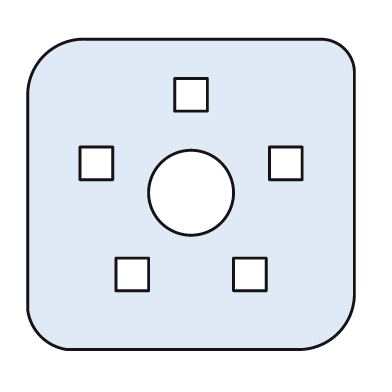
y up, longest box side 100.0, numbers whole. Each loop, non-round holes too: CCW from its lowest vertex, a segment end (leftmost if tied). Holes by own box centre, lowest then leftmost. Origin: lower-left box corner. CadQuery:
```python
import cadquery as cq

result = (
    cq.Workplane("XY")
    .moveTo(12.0, 0.0)
    .lineTo(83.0, 0.0)
    .threePointArc((95.0, 5.0), (100.0, 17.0))
    .lineTo(100.0, 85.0)
    .threePointArc((97.0, 92.0), (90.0, 95.0))
    .lineTo(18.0, 95.0)
    .threePointArc((5.0, 90.0), (0.0, 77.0))
    .lineTo(0.0, 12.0)
    .threePointArc((4.0, 4.0), (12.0, 0.0))
    .close()
    .moveTo(27.0, 18.0)
    .lineTo(37.0, 18.0)
    .lineTo(37.0, 28.0)
    .lineTo(27.0, 28.0)
    .close()
    .moveTo(63.0, 18.0)
    .lineTo(73.0, 18.0)
    .lineTo(73.0, 28.0)
    .lineTo(63.0, 28.0)
    .close()
    .moveTo(50.0, 48.0)
    .circle(13.0)
    .moveTo(16.0, 52.0)
    .lineTo(26.0, 52.0)
    .lineTo(26.0, 62.0)
    .lineTo(16.0, 62.0)
    .close()
    .moveTo(74.0, 52.0)
    .lineTo(84.0, 52.0)
    .lineTo(84.0, 62.0)
    .lineTo(74.0, 62.0)
    .close()
    .moveTo(45.0, 73.0)
    .lineTo(55.0, 73.0)
    .lineTo(55.0, 83.0)
    .lineTo(45.0, 83.0)
    .close()
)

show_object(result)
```